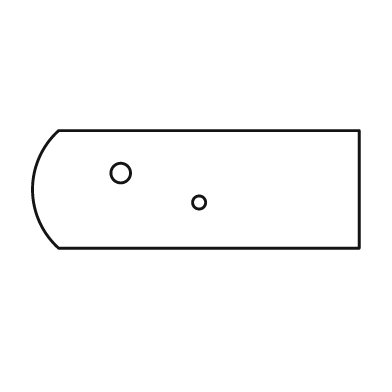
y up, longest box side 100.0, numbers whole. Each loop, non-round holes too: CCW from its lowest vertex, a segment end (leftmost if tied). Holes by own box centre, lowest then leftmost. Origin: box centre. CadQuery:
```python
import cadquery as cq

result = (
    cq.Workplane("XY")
    .moveTo(-42.0, -18.0)
    .lineTo(50.0, -18.0)
    .lineTo(50.0, 18.0)
    .lineTo(-42.0, 18.0)
    .threePointArc((-50.0, 0.0), (-42.0, -18.0))
    .close()
    .moveTo(1.0, -4.0)
    .circle(2.0)
    .moveTo(-23.0, 5.0)
    .circle(3.0)
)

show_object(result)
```